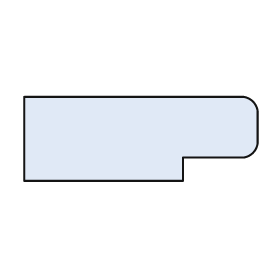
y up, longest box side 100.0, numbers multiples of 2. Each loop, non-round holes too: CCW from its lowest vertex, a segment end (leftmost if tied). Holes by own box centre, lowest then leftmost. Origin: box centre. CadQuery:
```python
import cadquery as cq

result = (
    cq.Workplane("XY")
    .moveTo(-50.0, -18.0)
    .lineTo(18.0, -18.0)
    .lineTo(18.0, -8.0)
    .lineTo(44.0, -8.0)
    .threePointArc((48.0, -6.0), (50.0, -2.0))
    .lineTo(50.0, 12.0)
    .threePointArc((48.0, 16.0), (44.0, 18.0))
    .lineTo(-50.0, 18.0)
    .close()
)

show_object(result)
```